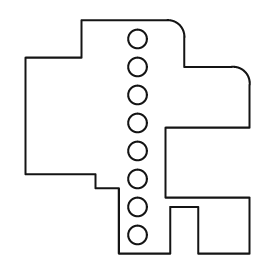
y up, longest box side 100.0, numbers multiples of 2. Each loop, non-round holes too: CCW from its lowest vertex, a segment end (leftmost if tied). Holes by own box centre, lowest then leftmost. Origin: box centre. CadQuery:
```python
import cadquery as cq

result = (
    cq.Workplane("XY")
    .moveTo(-8.0, -50.0)
    .lineTo(14.0, -50.0)
    .lineTo(14.0, -30.0)
    .lineTo(26.0, -30.0)
    .lineTo(26.0, -50.0)
    .lineTo(48.0, -50.0)
    .lineTo(48.0, -26.0)
    .lineTo(12.0, -26.0)
    .lineTo(12.0, 4.0)
    .lineTo(48.0, 4.0)
    .lineTo(48.0, 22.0)
    .threePointArc((46.0, 28.0), (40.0, 30.0))
    .lineTo(20.0, 30.0)
    .lineTo(20.0, 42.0)
    .threePointArc((18.0, 48.0), (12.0, 50.0))
    .lineTo(-24.0, 50.0)
    .lineTo(-24.0, 34.0)
    .lineTo(-48.0, 34.0)
    .lineTo(-48.0, -16.0)
    .lineTo(-18.0, -16.0)
    .lineTo(-18.0, -22.0)
    .lineTo(-8.0, -22.0)
    .close()
    .moveTo(0.0, -42.0)
    .circle(4.0)
    .moveTo(0.0, -30.0)
    .circle(4.0)
    .moveTo(0.0, -18.0)
    .circle(4.0)
    .moveTo(0.0, -6.0)
    .circle(4.0)
    .moveTo(0.0, 6.0)
    .circle(4.0)
    .moveTo(0.0, 18.0)
    .circle(4.0)
    .moveTo(0.0, 30.0)
    .circle(4.0)
    .moveTo(0.0, 42.0)
    .circle(4.0)
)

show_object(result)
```